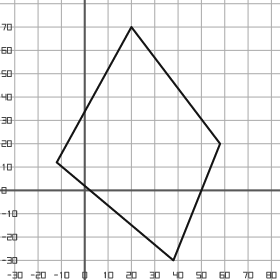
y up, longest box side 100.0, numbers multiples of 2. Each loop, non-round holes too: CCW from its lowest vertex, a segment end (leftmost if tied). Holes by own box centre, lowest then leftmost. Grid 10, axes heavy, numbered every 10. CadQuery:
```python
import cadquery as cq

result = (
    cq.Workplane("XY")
    .moveTo(38.0, -30.0)
    .lineTo(58.0, 20.0)
    .lineTo(20.0, 70.0)
    .lineTo(-12.0, 12.0)
    .close()
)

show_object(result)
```